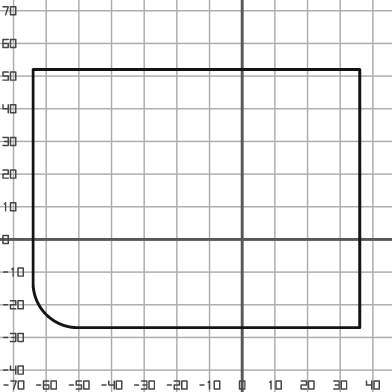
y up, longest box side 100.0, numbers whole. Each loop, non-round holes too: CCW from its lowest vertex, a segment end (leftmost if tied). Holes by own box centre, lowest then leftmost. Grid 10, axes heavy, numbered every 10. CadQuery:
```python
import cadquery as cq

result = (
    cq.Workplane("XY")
    .moveTo(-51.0, -27.0)
    .lineTo(36.0, -27.0)
    .lineTo(36.0, 52.0)
    .lineTo(-64.0, 52.0)
    .lineTo(-64.0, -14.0)
    .threePointArc((-60.0, -23.0), (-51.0, -27.0))
    .close()
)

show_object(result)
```